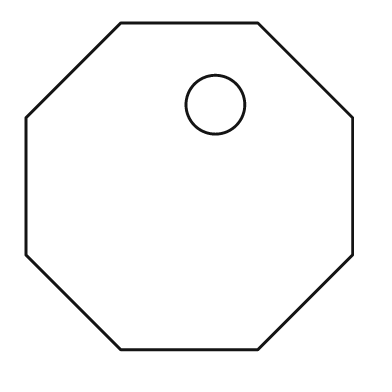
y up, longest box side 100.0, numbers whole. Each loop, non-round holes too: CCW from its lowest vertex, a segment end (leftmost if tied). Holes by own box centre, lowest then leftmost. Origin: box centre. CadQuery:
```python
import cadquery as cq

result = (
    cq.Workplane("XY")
    .moveTo(-21.0, -50.0)
    .lineTo(21.0, -50.0)
    .lineTo(50.0, -21.0)
    .lineTo(50.0, 21.0)
    .lineTo(21.0, 50.0)
    .lineTo(-21.0, 50.0)
    .lineTo(-50.0, 21.0)
    .lineTo(-50.0, -21.0)
    .close()
    .moveTo(8.0, 25.0)
    .circle(9.0)
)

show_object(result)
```